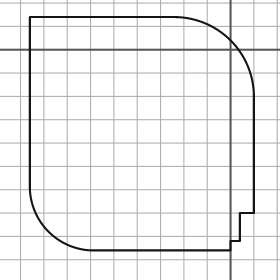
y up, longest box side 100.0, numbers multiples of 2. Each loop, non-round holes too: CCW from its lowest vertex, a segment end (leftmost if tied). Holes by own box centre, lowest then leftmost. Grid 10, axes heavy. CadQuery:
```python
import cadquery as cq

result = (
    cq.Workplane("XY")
    .moveTo(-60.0, -86.0)
    .lineTo(0.0, -86.0)
    .lineTo(0.0, -82.0)
    .lineTo(4.0, -82.0)
    .lineTo(4.0, -70.0)
    .lineTo(10.0, -70.0)
    .lineTo(10.0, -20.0)
    .threePointArc((0.0, 4.0), (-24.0, 14.0))
    .lineTo(-86.0, 14.0)
    .lineTo(-86.0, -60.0)
    .threePointArc((-78.0, -78.0), (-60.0, -86.0))
    .close()
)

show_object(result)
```